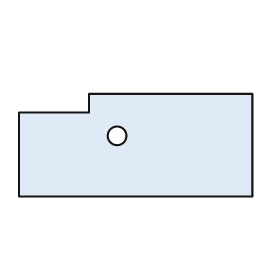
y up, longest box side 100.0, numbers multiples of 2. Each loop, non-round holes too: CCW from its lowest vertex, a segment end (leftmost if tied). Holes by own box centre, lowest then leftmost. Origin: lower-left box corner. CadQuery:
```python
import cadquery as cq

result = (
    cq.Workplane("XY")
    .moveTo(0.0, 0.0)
    .lineTo(100.0, 0.0)
    .lineTo(100.0, 44.0)
    .lineTo(30.0, 44.0)
    .lineTo(30.0, 36.0)
    .lineTo(0.0, 36.0)
    .close()
    .moveTo(42.0, 26.0)
    .circle(4.0)
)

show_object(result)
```